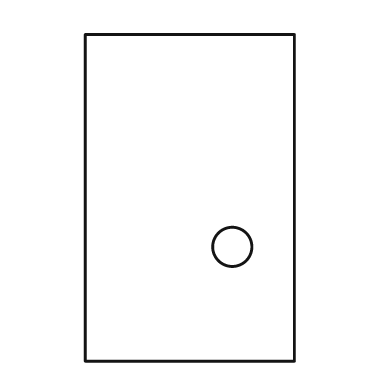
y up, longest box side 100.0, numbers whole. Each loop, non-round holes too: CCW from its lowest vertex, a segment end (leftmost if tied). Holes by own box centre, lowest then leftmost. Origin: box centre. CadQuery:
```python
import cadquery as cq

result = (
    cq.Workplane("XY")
    .moveTo(-32.0, -50.0)
    .lineTo(32.0, -50.0)
    .lineTo(32.0, 50.0)
    .lineTo(-32.0, 50.0)
    .close()
    .moveTo(13.0, -15.0)
    .circle(6.0)
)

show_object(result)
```